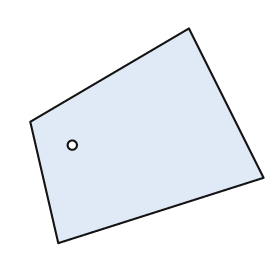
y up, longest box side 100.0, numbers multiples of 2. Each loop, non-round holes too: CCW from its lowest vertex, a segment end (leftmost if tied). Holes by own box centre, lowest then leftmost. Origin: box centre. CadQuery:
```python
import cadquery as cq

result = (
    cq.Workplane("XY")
    .moveTo(-38.0, -46.0)
    .lineTo(50.0, -18.0)
    .lineTo(18.0, 46.0)
    .lineTo(-50.0, 6.0)
    .close()
    .moveTo(-32.0, -4.0)
    .circle(2.0)
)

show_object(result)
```